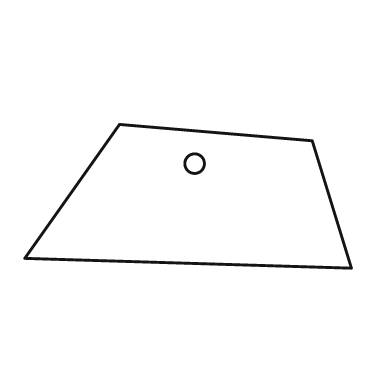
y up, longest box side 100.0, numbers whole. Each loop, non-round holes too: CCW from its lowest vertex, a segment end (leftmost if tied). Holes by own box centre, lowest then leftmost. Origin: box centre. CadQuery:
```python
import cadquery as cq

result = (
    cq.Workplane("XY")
    .moveTo(50.0, -22.0)
    .lineTo(38.0, 17.0)
    .lineTo(-21.0, 22.0)
    .lineTo(-50.0, -19.0)
    .close()
    .moveTo(2.0, 10.0)
    .circle(3.0)
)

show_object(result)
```